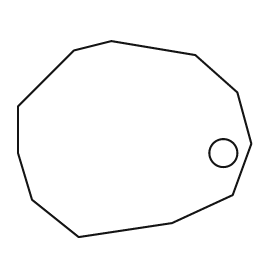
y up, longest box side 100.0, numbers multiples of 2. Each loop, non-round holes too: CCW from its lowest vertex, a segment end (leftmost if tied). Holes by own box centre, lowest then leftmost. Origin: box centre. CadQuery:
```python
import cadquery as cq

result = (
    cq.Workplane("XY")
    .moveTo(-24.0, -42.0)
    .lineTo(16.0, -36.0)
    .lineTo(42.0, -24.0)
    .lineTo(50.0, -2.0)
    .lineTo(44.0, 20.0)
    .lineTo(26.0, 36.0)
    .lineTo(-10.0, 42.0)
    .lineTo(-26.0, 38.0)
    .lineTo(-50.0, 14.0)
    .lineTo(-50.0, -6.0)
    .lineTo(-44.0, -26.0)
    .close()
    .moveTo(38.0, -6.0)
    .circle(6.0)
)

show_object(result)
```